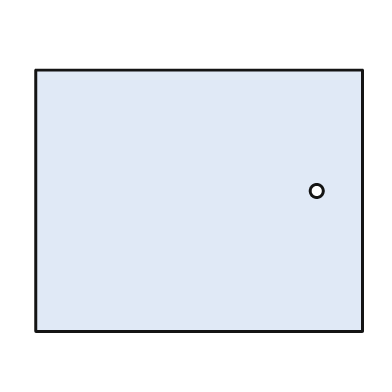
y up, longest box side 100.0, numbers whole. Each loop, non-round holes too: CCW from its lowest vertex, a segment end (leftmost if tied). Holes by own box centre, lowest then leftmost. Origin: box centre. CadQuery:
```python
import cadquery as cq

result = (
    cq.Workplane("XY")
    .moveTo(-50.0, -40.0)
    .lineTo(50.0, -40.0)
    .lineTo(50.0, 40.0)
    .lineTo(-50.0, 40.0)
    .close()
    .moveTo(36.0, 3.0)
    .circle(2.0)
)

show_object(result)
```